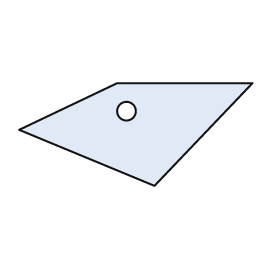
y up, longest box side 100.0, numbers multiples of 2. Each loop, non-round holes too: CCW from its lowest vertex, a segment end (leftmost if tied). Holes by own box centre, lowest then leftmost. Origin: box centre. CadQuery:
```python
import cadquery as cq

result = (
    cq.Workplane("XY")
    .moveTo(8.0, -22.0)
    .lineTo(50.0, 22.0)
    .lineTo(-8.0, 22.0)
    .lineTo(-50.0, 2.0)
    .close()
    .moveTo(-4.0, 10.0)
    .circle(4.0)
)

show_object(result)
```